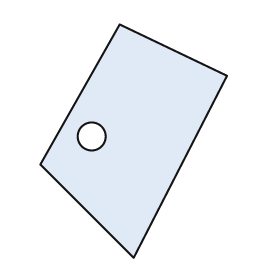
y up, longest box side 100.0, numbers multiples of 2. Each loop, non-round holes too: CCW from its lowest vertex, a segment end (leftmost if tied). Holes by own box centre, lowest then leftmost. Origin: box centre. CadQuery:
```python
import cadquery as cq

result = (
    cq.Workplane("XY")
    .moveTo(0.0, -50.0)
    .lineTo(40.0, 28.0)
    .lineTo(-6.0, 50.0)
    .lineTo(-40.0, -10.0)
    .close()
    .moveTo(-18.0, 2.0)
    .circle(6.0)
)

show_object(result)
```